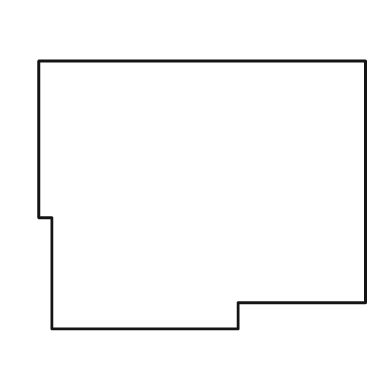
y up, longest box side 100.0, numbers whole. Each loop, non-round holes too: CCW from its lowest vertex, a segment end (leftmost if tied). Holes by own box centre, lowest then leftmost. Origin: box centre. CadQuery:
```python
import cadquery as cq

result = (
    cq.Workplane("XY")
    .moveTo(-46.0, -41.0)
    .lineTo(11.0, -41.0)
    .lineTo(11.0, -33.0)
    .lineTo(50.0, -33.0)
    .lineTo(50.0, 41.0)
    .lineTo(-50.0, 41.0)
    .lineTo(-50.0, -7.0)
    .lineTo(-46.0, -7.0)
    .close()
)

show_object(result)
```